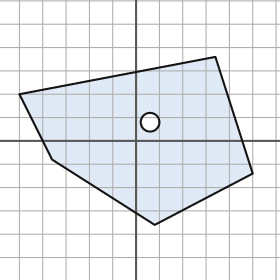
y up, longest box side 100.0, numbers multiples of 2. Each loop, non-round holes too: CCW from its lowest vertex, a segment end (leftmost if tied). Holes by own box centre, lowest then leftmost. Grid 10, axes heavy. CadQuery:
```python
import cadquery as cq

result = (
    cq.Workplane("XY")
    .moveTo(8.0, -36.0)
    .lineTo(50.0, -14.0)
    .lineTo(34.0, 36.0)
    .lineTo(-50.0, 20.0)
    .lineTo(-36.0, -8.0)
    .close()
    .moveTo(6.0, 8.0)
    .circle(4.0)
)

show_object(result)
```